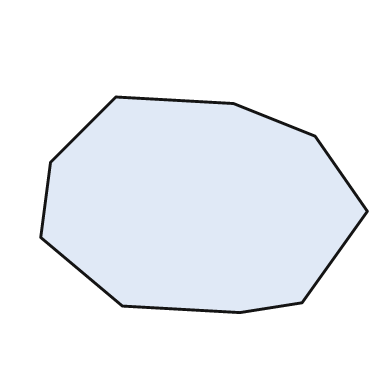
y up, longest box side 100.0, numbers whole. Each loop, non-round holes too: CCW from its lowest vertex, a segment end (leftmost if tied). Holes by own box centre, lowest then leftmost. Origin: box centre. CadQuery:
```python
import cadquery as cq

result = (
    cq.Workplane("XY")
    .moveTo(11.0, -33.0)
    .lineTo(30.0, -30.0)
    .lineTo(50.0, -2.0)
    .lineTo(34.0, 21.0)
    .lineTo(9.0, 31.0)
    .lineTo(-27.0, 33.0)
    .lineTo(-47.0, 13.0)
    .lineTo(-50.0, -10.0)
    .lineTo(-25.0, -31.0)
    .close()
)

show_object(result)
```